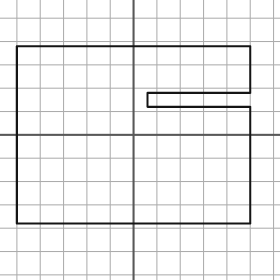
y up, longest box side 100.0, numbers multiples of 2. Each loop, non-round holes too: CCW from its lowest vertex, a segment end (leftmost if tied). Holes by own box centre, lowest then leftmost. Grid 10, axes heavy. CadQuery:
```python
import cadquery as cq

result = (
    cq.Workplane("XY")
    .moveTo(-50.0, -38.0)
    .lineTo(50.0, -38.0)
    .lineTo(50.0, 12.0)
    .lineTo(6.0, 12.0)
    .lineTo(6.0, 18.0)
    .lineTo(50.0, 18.0)
    .lineTo(50.0, 38.0)
    .lineTo(-50.0, 38.0)
    .close()
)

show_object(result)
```